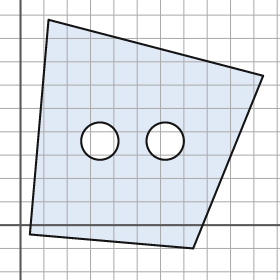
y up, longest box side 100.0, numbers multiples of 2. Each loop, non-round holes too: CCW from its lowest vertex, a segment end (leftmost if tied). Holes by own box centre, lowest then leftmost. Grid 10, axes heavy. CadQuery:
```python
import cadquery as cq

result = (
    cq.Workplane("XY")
    .moveTo(74.0, -10.0)
    .lineTo(104.0, 64.0)
    .lineTo(12.0, 88.0)
    .lineTo(4.0, -4.0)
    .close()
    .moveTo(34.0, 36.0)
    .circle(8.0)
    .moveTo(62.0, 36.0)
    .circle(8.0)
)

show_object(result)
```